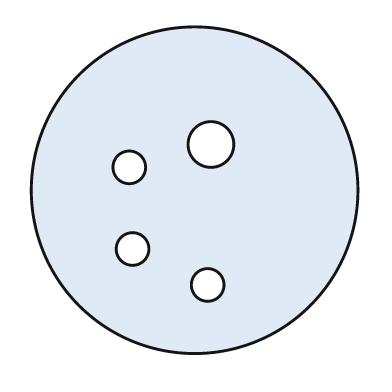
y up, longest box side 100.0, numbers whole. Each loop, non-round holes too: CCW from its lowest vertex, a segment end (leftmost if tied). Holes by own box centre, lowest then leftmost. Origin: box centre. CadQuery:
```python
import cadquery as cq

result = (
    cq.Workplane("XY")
    .moveTo(0.0, 0.0)
    .circle(50.0)
    .moveTo(4.0, -29.0)
    .circle(5.0)
    .moveTo(-19.0, -18.0)
    .circle(5.0)
    .moveTo(-20.0, 7.0)
    .circle(5.0)
    .moveTo(5.0, 14.0)
    .circle(7.0)
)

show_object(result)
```